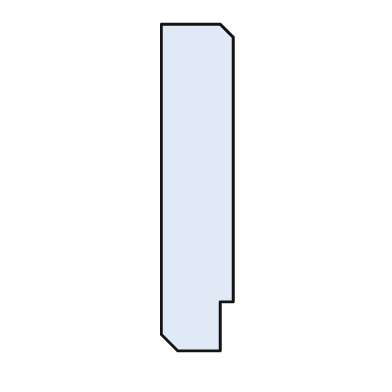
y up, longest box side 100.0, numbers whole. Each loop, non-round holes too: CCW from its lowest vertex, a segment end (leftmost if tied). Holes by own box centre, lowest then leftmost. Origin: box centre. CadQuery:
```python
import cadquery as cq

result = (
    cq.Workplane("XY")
    .moveTo(-6.0, -50.0)
    .lineTo(7.0, -50.0)
    .lineTo(7.0, -35.0)
    .lineTo(11.0, -35.0)
    .lineTo(11.0, 46.0)
    .lineTo(7.0, 50.0)
    .lineTo(-11.0, 50.0)
    .lineTo(-11.0, -45.0)
    .close()
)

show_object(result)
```